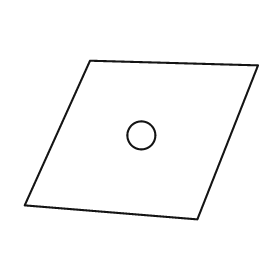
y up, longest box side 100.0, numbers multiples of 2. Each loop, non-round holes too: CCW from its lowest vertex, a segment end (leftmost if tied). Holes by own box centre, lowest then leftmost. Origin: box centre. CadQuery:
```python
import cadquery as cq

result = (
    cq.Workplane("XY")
    .moveTo(24.0, -34.0)
    .lineTo(50.0, 32.0)
    .lineTo(-22.0, 34.0)
    .lineTo(-50.0, -28.0)
    .close()
    .moveTo(0.0, 2.0)
    .circle(6.0)
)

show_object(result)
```